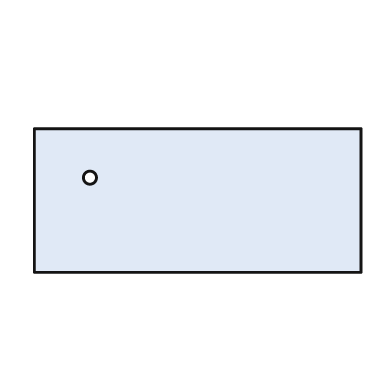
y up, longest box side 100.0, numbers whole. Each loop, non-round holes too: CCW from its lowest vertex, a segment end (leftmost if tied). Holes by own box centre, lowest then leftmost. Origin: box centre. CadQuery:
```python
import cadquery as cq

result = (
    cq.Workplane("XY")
    .moveTo(-50.0, -22.0)
    .lineTo(50.0, -22.0)
    .lineTo(50.0, 22.0)
    .lineTo(-50.0, 22.0)
    .close()
    .moveTo(-33.0, 7.0)
    .circle(2.0)
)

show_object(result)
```